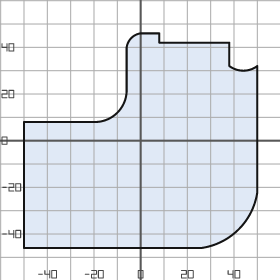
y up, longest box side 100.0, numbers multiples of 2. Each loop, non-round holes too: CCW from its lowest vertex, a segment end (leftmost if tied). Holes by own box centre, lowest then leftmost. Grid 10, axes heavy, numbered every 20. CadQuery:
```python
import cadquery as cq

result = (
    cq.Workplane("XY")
    .moveTo(-50.0, -46.0)
    .lineTo(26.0, -46.0)
    .threePointArc((42.0, -38.0), (50.0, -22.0))
    .lineTo(50.0, 32.0)
    .threePointArc((44.0, 30.0), (38.0, 32.0))
    .lineTo(38.0, 42.0)
    .lineTo(8.0, 42.0)
    .lineTo(8.0, 46.0)
    .lineTo(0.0, 46.0)
    .threePointArc((-4.0, 44.0), (-6.0, 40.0))
    .lineTo(-6.0, 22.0)
    .threePointArc((-10.0, 12.0), (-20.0, 8.0))
    .lineTo(-50.0, 8.0)
    .close()
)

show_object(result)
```